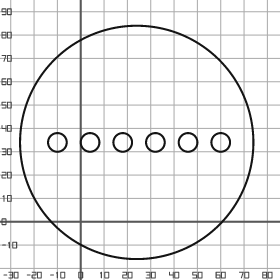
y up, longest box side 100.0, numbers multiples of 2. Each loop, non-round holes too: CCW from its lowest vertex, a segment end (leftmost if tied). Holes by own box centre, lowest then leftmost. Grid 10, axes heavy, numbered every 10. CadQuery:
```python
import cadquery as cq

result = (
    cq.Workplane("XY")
    .moveTo(24.0, 34.0)
    .circle(50.0)
    .moveTo(-10.0, 34.0)
    .circle(4.0)
    .moveTo(4.0, 34.0)
    .circle(4.0)
    .moveTo(18.0, 34.0)
    .circle(4.0)
    .moveTo(32.0, 34.0)
    .circle(4.0)
    .moveTo(46.0, 34.0)
    .circle(4.0)
    .moveTo(60.0, 34.0)
    .circle(4.0)
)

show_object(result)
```